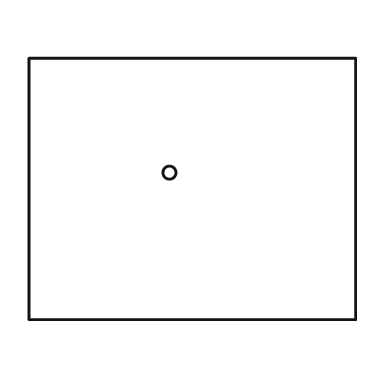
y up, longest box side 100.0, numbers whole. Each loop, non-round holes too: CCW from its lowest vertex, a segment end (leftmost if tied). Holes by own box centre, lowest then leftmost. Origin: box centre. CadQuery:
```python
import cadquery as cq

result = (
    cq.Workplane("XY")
    .moveTo(-50.0, -40.0)
    .lineTo(50.0, -40.0)
    .lineTo(50.0, 40.0)
    .lineTo(-50.0, 40.0)
    .close()
    .moveTo(-7.0, 5.0)
    .circle(2.0)
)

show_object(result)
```